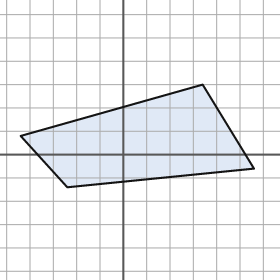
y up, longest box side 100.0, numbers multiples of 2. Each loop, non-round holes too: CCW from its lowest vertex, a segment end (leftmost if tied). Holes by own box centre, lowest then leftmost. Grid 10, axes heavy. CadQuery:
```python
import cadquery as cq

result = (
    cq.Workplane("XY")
    .moveTo(-24.0, -14.0)
    .lineTo(56.0, -6.0)
    .lineTo(34.0, 30.0)
    .lineTo(-44.0, 8.0)
    .close()
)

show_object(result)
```